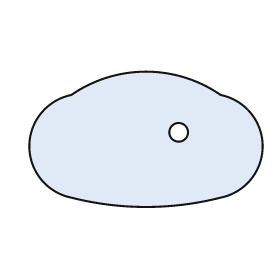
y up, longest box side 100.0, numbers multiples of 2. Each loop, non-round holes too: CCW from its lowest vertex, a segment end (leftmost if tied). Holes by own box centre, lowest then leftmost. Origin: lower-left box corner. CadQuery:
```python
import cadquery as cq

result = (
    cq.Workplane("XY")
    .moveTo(18.0, 4.0)
    .threePointArc((50.0, 0.0), (82.0, 4.0))
    .threePointArc((100.0, 26.0), (82.0, 48.0))
    .threePointArc((50.0, 58.0), (18.0, 48.0))
    .threePointArc((0.0, 26.0), (18.0, 4.0))
    .close()
    .moveTo(64.0, 32.0)
    .circle(4.0)
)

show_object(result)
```